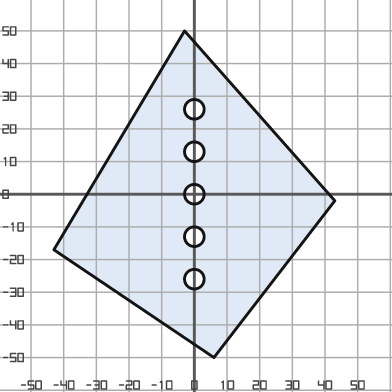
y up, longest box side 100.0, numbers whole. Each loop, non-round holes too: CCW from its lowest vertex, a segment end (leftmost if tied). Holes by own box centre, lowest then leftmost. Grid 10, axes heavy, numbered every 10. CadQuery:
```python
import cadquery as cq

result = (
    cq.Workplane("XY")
    .moveTo(6.0, -50.0)
    .lineTo(43.0, -2.0)
    .lineTo(-3.0, 50.0)
    .lineTo(-43.0, -17.0)
    .close()
    .moveTo(0.0, -26.0)
    .circle(3.0)
    .moveTo(0.0, -13.0)
    .circle(3.0)
    .moveTo(0.0, 0.0)
    .circle(3.0)
    .moveTo(0.0, 13.0)
    .circle(3.0)
    .moveTo(0.0, 26.0)
    .circle(3.0)
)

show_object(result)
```